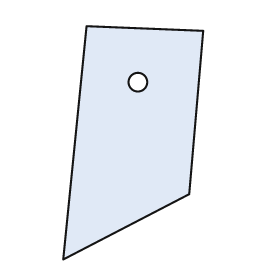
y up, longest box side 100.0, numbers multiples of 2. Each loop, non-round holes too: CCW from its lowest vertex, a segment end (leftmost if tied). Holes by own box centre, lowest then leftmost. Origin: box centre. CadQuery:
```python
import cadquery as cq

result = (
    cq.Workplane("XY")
    .moveTo(-30.0, -50.0)
    .lineTo(24.0, -22.0)
    .lineTo(30.0, 48.0)
    .lineTo(-20.0, 50.0)
    .close()
    .moveTo(2.0, 26.0)
    .circle(4.0)
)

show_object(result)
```